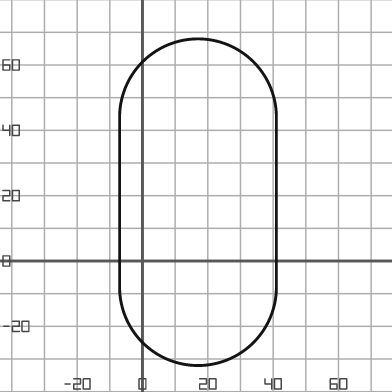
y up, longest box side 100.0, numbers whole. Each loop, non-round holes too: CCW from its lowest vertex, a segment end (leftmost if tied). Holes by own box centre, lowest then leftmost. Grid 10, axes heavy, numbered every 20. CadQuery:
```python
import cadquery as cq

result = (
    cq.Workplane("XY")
    .moveTo(-7.0, -8.0)
    .threePointArc((17.0, -32.0), (41.0, -8.0))
    .lineTo(41.0, 44.0)
    .threePointArc((17.0, 68.0), (-7.0, 44.0))
    .close()
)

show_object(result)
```